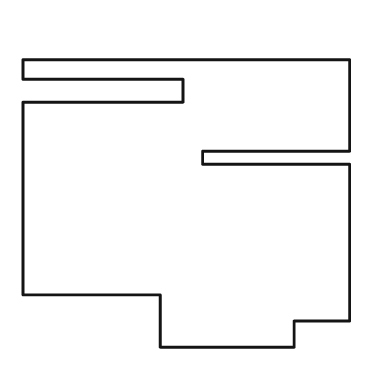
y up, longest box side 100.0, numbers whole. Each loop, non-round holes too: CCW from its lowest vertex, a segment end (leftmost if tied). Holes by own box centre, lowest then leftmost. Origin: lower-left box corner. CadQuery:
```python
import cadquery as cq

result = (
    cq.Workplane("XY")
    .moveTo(42.0, 0.0)
    .lineTo(83.0, 0.0)
    .lineTo(83.0, 8.0)
    .lineTo(100.0, 8.0)
    .lineTo(100.0, 56.0)
    .lineTo(55.0, 56.0)
    .lineTo(55.0, 60.0)
    .lineTo(100.0, 60.0)
    .lineTo(100.0, 88.0)
    .lineTo(0.0, 88.0)
    .lineTo(0.0, 82.0)
    .lineTo(49.0, 82.0)
    .lineTo(49.0, 75.0)
    .lineTo(0.0, 75.0)
    .lineTo(0.0, 16.0)
    .lineTo(42.0, 16.0)
    .close()
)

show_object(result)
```